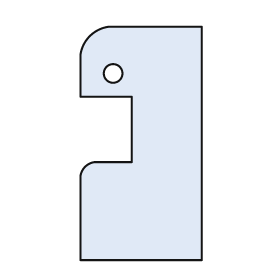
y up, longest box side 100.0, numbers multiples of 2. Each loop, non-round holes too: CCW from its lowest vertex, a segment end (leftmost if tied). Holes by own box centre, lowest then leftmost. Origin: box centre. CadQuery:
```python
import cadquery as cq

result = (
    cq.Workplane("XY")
    .moveTo(-26.0, -50.0)
    .lineTo(26.0, -50.0)
    .lineTo(26.0, 50.0)
    .lineTo(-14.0, 50.0)
    .threePointArc((-22.0, 46.0), (-26.0, 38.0))
    .lineTo(-26.0, 20.0)
    .lineTo(-4.0, 20.0)
    .lineTo(-4.0, -8.0)
    .lineTo(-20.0, -8.0)
    .threePointArc((-24.0, -10.0), (-26.0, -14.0))
    .close()
    .moveTo(-12.0, 30.0)
    .circle(4.0)
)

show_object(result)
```